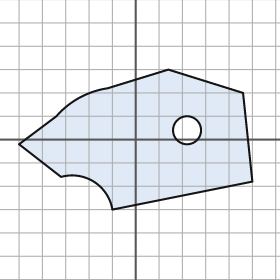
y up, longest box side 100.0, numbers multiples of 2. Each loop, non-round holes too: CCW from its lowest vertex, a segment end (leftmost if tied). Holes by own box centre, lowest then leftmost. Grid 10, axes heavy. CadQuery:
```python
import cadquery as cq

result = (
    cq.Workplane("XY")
    .moveTo(-10.0, -30.0)
    .lineTo(50.0, -18.0)
    .lineTo(46.0, 20.0)
    .lineTo(14.0, 30.0)
    .lineTo(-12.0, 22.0)
    .threePointArc((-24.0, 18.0), (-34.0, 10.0))
    .lineTo(-50.0, -2.0)
    .lineTo(-32.0, -16.0)
    .threePointArc((-18.0, -18.0), (-10.0, -30.0))
    .close()
    .moveTo(22.0, 4.0)
    .circle(6.0)
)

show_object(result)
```